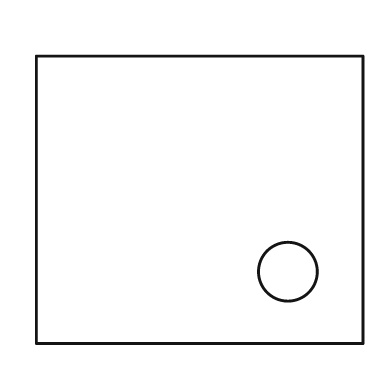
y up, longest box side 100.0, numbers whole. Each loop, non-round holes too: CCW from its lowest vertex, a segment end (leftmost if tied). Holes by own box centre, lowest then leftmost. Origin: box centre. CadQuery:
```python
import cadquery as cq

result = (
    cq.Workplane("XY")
    .moveTo(-50.0, -44.0)
    .lineTo(50.0, -44.0)
    .lineTo(50.0, 44.0)
    .lineTo(-50.0, 44.0)
    .close()
    .moveTo(27.0, -22.0)
    .circle(9.0)
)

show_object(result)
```